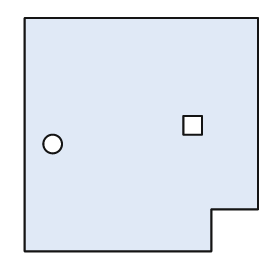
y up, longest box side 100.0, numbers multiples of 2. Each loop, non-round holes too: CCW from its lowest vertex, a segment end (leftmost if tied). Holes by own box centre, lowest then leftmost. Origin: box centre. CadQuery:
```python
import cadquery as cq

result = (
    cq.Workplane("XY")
    .moveTo(-50.0, -50.0)
    .lineTo(30.0, -50.0)
    .lineTo(30.0, -32.0)
    .lineTo(50.0, -32.0)
    .lineTo(50.0, 50.0)
    .lineTo(-50.0, 50.0)
    .close()
    .moveTo(-38.0, -4.0)
    .circle(4.0)
    .moveTo(18.0, 0.0)
    .lineTo(26.0, 0.0)
    .lineTo(26.0, 8.0)
    .lineTo(18.0, 8.0)
    .close()
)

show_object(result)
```